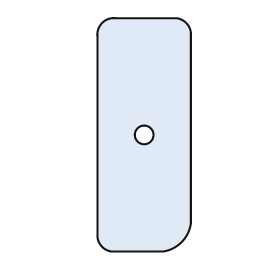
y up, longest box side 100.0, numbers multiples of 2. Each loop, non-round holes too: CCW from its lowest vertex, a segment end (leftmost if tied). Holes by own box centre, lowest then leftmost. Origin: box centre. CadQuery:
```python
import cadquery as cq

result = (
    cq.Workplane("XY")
    .moveTo(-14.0, -50.0)
    .lineTo(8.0, -50.0)
    .threePointArc((16.0, -46.0), (20.0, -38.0))
    .lineTo(20.0, 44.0)
    .threePointArc((18.0, 48.0), (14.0, 50.0))
    .lineTo(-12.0, 50.0)
    .threePointArc((-18.0, 48.0), (-20.0, 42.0))
    .lineTo(-20.0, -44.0)
    .threePointArc((-18.0, -48.0), (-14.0, -50.0))
    .close()
    .moveTo(0.0, 0.0)
    .circle(4.0)
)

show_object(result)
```